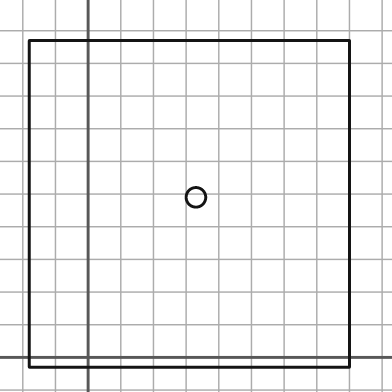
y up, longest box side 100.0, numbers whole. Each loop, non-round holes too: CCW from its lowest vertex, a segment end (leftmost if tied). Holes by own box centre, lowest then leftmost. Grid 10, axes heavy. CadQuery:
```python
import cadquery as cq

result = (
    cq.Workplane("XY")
    .moveTo(-18.0, -3.0)
    .lineTo(80.0, -3.0)
    .lineTo(80.0, 97.0)
    .lineTo(-18.0, 97.0)
    .close()
    .moveTo(33.0, 49.0)
    .circle(3.0)
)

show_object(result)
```